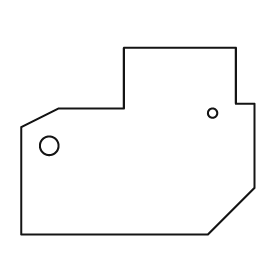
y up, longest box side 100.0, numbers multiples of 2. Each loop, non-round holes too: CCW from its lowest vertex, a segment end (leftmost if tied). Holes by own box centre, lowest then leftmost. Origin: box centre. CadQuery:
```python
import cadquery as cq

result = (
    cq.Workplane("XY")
    .moveTo(-50.0, -40.0)
    .lineTo(30.0, -40.0)
    .lineTo(50.0, -20.0)
    .lineTo(50.0, 16.0)
    .lineTo(42.0, 16.0)
    .lineTo(42.0, 40.0)
    .lineTo(-6.0, 40.0)
    .lineTo(-6.0, 14.0)
    .lineTo(-34.0, 14.0)
    .lineTo(-50.0, 6.0)
    .close()
    .moveTo(-38.0, -2.0)
    .circle(4.0)
    .moveTo(32.0, 12.0)
    .circle(2.0)
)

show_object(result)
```